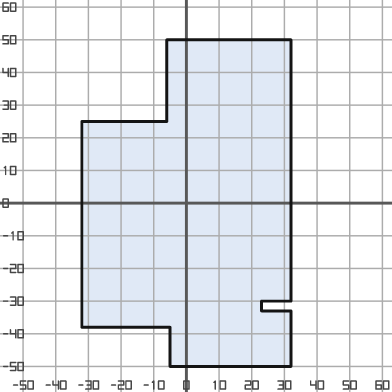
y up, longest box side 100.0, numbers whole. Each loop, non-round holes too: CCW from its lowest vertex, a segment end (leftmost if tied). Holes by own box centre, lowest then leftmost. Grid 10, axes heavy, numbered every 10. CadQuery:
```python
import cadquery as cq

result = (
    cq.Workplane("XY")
    .moveTo(-5.0, -50.0)
    .lineTo(32.0, -50.0)
    .lineTo(32.0, -33.0)
    .lineTo(23.0, -33.0)
    .lineTo(23.0, -30.0)
    .lineTo(32.0, -30.0)
    .lineTo(32.0, 50.0)
    .lineTo(-6.0, 50.0)
    .lineTo(-6.0, 25.0)
    .lineTo(-32.0, 25.0)
    .lineTo(-32.0, -38.0)
    .lineTo(-5.0, -38.0)
    .close()
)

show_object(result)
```